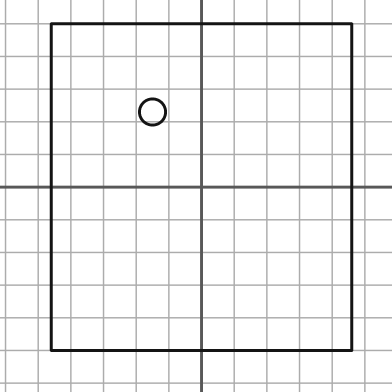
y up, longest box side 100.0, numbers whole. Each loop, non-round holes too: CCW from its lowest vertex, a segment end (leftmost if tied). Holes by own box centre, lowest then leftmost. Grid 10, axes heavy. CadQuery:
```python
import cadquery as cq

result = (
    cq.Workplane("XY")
    .moveTo(-46.0, -50.0)
    .lineTo(46.0, -50.0)
    .lineTo(46.0, 50.0)
    .lineTo(-46.0, 50.0)
    .close()
    .moveTo(-15.0, 23.0)
    .circle(4.0)
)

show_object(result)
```